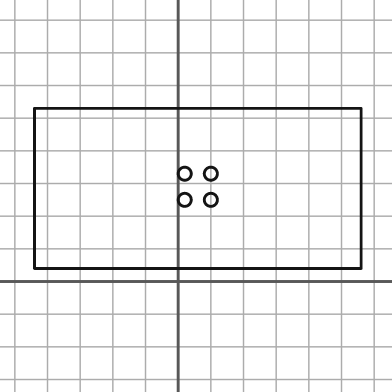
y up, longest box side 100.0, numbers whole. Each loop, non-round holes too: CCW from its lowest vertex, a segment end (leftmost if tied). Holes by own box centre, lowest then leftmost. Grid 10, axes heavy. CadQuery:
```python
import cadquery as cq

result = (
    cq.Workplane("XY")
    .moveTo(-44.0, 4.0)
    .lineTo(56.0, 4.0)
    .lineTo(56.0, 53.0)
    .lineTo(-44.0, 53.0)
    .close()
    .moveTo(2.0, 25.0)
    .circle(2.0)
    .moveTo(10.0, 25.0)
    .circle(2.0)
    .moveTo(2.0, 33.0)
    .circle(2.0)
    .moveTo(10.0, 33.0)
    .circle(2.0)
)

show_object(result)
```